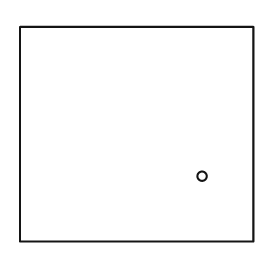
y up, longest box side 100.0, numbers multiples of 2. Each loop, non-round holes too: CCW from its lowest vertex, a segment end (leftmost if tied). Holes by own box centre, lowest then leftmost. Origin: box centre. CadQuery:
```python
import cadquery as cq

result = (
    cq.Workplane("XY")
    .moveTo(-50.0, -46.0)
    .lineTo(50.0, -46.0)
    .lineTo(50.0, 46.0)
    .lineTo(-50.0, 46.0)
    .close()
    .moveTo(28.0, -18.0)
    .circle(2.0)
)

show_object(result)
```